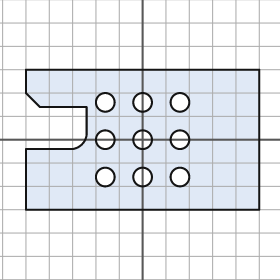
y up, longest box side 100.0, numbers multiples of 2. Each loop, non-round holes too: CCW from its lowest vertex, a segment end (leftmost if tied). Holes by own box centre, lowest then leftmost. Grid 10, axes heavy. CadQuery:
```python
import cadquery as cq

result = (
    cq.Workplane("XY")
    .moveTo(-50.0, -30.0)
    .lineTo(50.0, -30.0)
    .lineTo(50.0, 30.0)
    .lineTo(-50.0, 30.0)
    .lineTo(-50.0, 20.0)
    .lineTo(-44.0, 14.0)
    .lineTo(-24.0, 14.0)
    .lineTo(-24.0, 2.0)
    .threePointArc((-26.0, -2.0), (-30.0, -4.0))
    .lineTo(-50.0, -4.0)
    .close()
    .moveTo(-16.0, -16.0)
    .circle(4.0)
    .moveTo(0.0, -16.0)
    .circle(4.0)
    .moveTo(16.0, -16.0)
    .circle(4.0)
    .moveTo(-16.0, 0.0)
    .circle(4.0)
    .moveTo(0.0, 0.0)
    .circle(4.0)
    .moveTo(16.0, 0.0)
    .circle(4.0)
    .moveTo(-16.0, 16.0)
    .circle(4.0)
    .moveTo(0.0, 16.0)
    .circle(4.0)
    .moveTo(16.0, 16.0)
    .circle(4.0)
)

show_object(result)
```